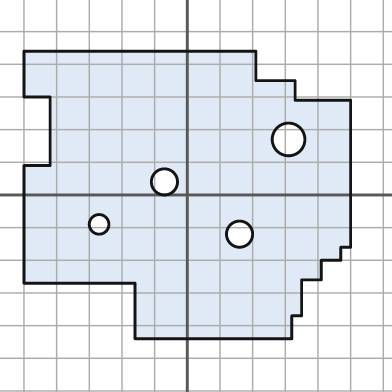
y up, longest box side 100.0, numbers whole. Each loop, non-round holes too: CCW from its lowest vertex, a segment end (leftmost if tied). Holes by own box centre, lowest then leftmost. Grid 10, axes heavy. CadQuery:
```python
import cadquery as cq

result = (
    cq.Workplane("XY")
    .moveTo(-16.0, -44.0)
    .lineTo(32.0, -44.0)
    .lineTo(32.0, -37.0)
    .lineTo(35.0, -37.0)
    .lineTo(35.0, -26.0)
    .lineTo(41.0, -26.0)
    .lineTo(41.0, -20.0)
    .lineTo(47.0, -20.0)
    .lineTo(47.0, -16.0)
    .lineTo(50.0, -16.0)
    .lineTo(50.0, 29.0)
    .lineTo(33.0, 29.0)
    .lineTo(33.0, 35.0)
    .lineTo(21.0, 35.0)
    .lineTo(21.0, 44.0)
    .lineTo(-50.0, 44.0)
    .lineTo(-50.0, 30.0)
    .lineTo(-42.0, 30.0)
    .lineTo(-42.0, 9.0)
    .lineTo(-50.0, 9.0)
    .lineTo(-50.0, -27.0)
    .lineTo(-16.0, -27.0)
    .close()
    .moveTo(16.0, -12.0)
    .circle(4.0)
    .moveTo(-27.0, -9.0)
    .circle(3.0)
    .moveTo(-7.0, 4.0)
    .circle(4.0)
    .moveTo(31.0, 17.0)
    .circle(5.0)
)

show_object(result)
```